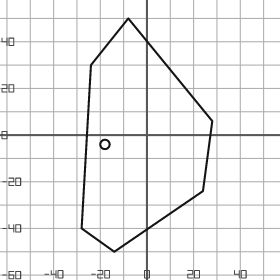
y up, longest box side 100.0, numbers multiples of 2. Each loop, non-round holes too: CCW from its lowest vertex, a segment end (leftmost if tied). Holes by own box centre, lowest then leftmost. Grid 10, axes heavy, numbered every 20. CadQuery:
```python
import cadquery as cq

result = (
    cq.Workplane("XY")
    .moveTo(-14.0, -50.0)
    .lineTo(24.0, -24.0)
    .lineTo(28.0, 6.0)
    .lineTo(-8.0, 50.0)
    .lineTo(-24.0, 30.0)
    .lineTo(-28.0, -40.0)
    .close()
    .moveTo(-18.0, -4.0)
    .circle(2.0)
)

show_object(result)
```